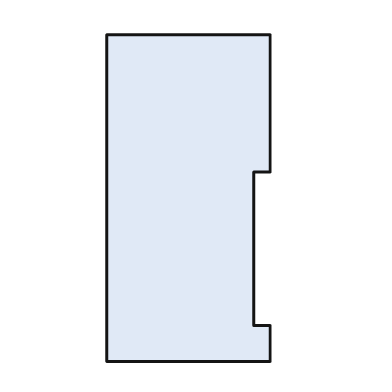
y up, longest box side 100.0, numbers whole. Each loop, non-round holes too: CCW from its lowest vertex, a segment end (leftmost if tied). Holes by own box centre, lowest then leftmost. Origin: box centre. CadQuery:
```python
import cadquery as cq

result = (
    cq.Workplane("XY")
    .moveTo(-25.0, -50.0)
    .lineTo(25.0, -50.0)
    .lineTo(25.0, -39.0)
    .lineTo(20.0, -39.0)
    .lineTo(20.0, 8.0)
    .lineTo(25.0, 8.0)
    .lineTo(25.0, 50.0)
    .lineTo(-25.0, 50.0)
    .close()
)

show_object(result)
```